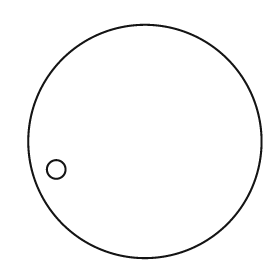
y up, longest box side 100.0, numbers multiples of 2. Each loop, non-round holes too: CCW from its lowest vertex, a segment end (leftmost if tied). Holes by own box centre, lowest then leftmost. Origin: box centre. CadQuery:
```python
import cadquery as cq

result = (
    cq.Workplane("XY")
    .moveTo(0.0, 0.0)
    .circle(50.0)
    .moveTo(-38.0, -12.0)
    .circle(4.0)
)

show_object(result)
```